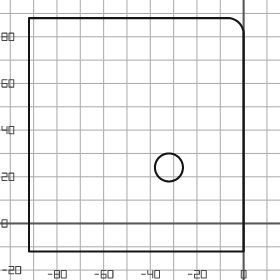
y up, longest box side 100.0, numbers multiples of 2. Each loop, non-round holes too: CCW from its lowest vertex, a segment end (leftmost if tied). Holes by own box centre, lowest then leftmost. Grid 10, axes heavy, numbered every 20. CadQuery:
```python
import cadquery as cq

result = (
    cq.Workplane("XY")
    .moveTo(-92.0, -12.0)
    .lineTo(0.0, -12.0)
    .lineTo(0.0, 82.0)
    .threePointArc((-2.0, 86.0), (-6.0, 88.0))
    .lineTo(-92.0, 88.0)
    .close()
    .moveTo(-32.0, 24.0)
    .circle(6.0)
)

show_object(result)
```